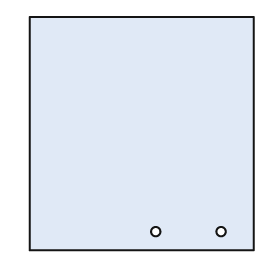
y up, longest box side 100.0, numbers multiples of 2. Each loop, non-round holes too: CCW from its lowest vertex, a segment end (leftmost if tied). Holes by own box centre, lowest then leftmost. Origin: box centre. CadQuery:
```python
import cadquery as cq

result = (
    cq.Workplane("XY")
    .moveTo(-48.0, -50.0)
    .lineTo(48.0, -50.0)
    .lineTo(48.0, 50.0)
    .lineTo(-48.0, 50.0)
    .close()
    .moveTo(6.0, -42.0)
    .circle(2.0)
    .moveTo(34.0, -42.0)
    .circle(2.0)
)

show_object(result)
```